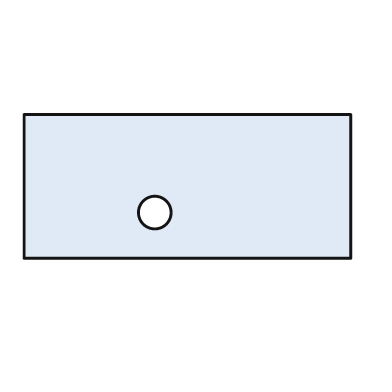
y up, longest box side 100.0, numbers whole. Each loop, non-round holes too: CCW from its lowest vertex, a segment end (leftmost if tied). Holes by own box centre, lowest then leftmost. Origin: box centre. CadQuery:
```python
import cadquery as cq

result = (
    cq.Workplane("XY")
    .moveTo(-50.0, -22.0)
    .lineTo(50.0, -22.0)
    .lineTo(50.0, 22.0)
    .lineTo(-50.0, 22.0)
    .close()
    .moveTo(-10.0, -8.0)
    .circle(5.0)
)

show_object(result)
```